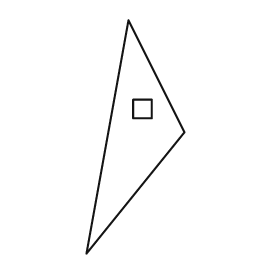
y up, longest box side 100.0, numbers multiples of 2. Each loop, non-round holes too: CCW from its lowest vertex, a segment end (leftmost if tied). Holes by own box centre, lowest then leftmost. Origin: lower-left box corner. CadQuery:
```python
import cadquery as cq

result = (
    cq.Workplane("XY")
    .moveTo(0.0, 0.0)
    .lineTo(42.0, 52.0)
    .lineTo(18.0, 100.0)
    .close()
    .moveTo(20.0, 58.0)
    .lineTo(28.0, 58.0)
    .lineTo(28.0, 66.0)
    .lineTo(20.0, 66.0)
    .close()
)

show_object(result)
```